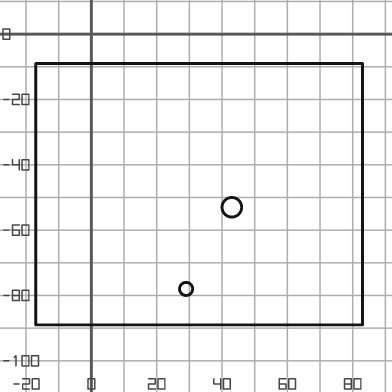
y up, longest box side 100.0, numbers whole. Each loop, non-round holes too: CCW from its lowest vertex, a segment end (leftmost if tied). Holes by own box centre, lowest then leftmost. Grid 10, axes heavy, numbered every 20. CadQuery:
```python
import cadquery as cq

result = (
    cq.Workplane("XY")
    .moveTo(-17.0, -89.0)
    .lineTo(83.0, -89.0)
    .lineTo(83.0, -9.0)
    .lineTo(-17.0, -9.0)
    .close()
    .moveTo(29.0, -78.0)
    .circle(2.0)
    .moveTo(43.0, -53.0)
    .circle(3.0)
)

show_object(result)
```